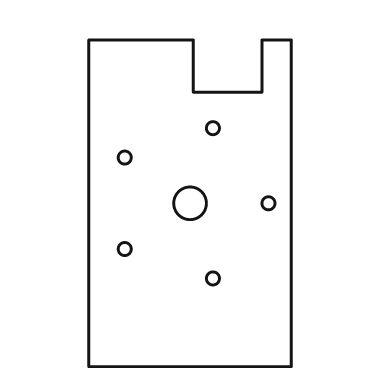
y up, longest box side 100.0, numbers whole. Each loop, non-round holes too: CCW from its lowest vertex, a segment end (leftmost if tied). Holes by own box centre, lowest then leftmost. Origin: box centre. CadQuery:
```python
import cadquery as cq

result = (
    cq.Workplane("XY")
    .moveTo(-31.0, -50.0)
    .lineTo(31.0, -50.0)
    .lineTo(31.0, 50.0)
    .lineTo(22.0, 50.0)
    .lineTo(22.0, 34.0)
    .lineTo(1.0, 34.0)
    .lineTo(1.0, 50.0)
    .lineTo(-31.0, 50.0)
    .close()
    .moveTo(7.0, -23.0)
    .circle(2.0)
    .moveTo(-20.0, -14.0)
    .circle(2.0)
    .moveTo(0.0, 0.0)
    .circle(5.0)
    .moveTo(24.0, 0.0)
    .circle(2.0)
    .moveTo(-20.0, 14.0)
    .circle(2.0)
    .moveTo(7.0, 23.0)
    .circle(2.0)
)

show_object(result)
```